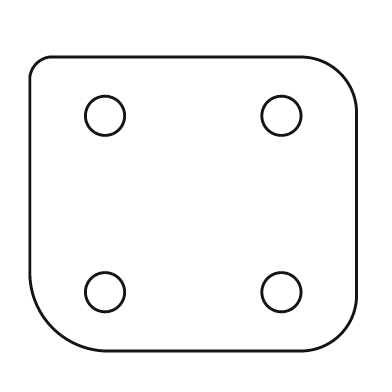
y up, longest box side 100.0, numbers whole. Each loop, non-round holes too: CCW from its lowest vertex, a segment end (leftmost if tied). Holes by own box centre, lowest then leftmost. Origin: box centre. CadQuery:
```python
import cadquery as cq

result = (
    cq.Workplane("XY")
    .moveTo(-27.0, -45.0)
    .lineTo(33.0, -45.0)
    .threePointArc((45.0, -40.0), (50.0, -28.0))
    .lineTo(50.0, 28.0)
    .threePointArc((45.0, 40.0), (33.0, 45.0))
    .lineTo(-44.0, 45.0)
    .threePointArc((-48.0, 43.0), (-50.0, 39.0))
    .lineTo(-50.0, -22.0)
    .threePointArc((-43.0, -38.0), (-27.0, -45.0))
    .close()
    .moveTo(-27.0, -27.0)
    .circle(6.0)
    .moveTo(27.0, -27.0)
    .circle(6.0)
    .moveTo(-27.0, 27.0)
    .circle(6.0)
    .moveTo(27.0, 27.0)
    .circle(6.0)
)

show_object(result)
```